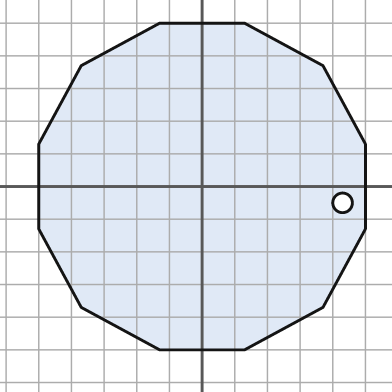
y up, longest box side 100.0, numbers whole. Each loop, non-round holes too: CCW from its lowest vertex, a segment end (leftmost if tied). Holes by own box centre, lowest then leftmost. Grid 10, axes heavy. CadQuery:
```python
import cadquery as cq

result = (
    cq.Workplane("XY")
    .moveTo(-13.0, -50.0)
    .lineTo(13.0, -50.0)
    .lineTo(37.0, -37.0)
    .lineTo(50.0, -13.0)
    .lineTo(50.0, 13.0)
    .lineTo(37.0, 37.0)
    .lineTo(13.0, 50.0)
    .lineTo(-13.0, 50.0)
    .lineTo(-37.0, 37.0)
    .lineTo(-50.0, 13.0)
    .lineTo(-50.0, -13.0)
    .lineTo(-37.0, -37.0)
    .close()
    .moveTo(43.0, -5.0)
    .circle(3.0)
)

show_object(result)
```